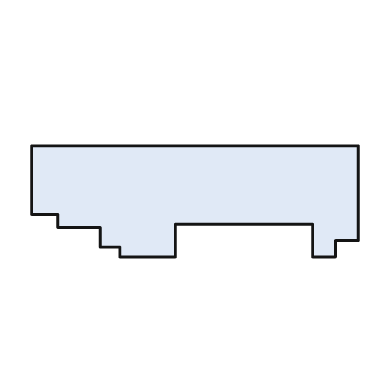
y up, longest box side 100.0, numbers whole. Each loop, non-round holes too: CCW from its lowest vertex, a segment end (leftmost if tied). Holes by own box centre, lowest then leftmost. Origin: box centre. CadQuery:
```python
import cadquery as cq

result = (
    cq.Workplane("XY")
    .moveTo(-23.0, -17.0)
    .lineTo(-6.0, -17.0)
    .lineTo(-6.0, -7.0)
    .lineTo(36.0, -7.0)
    .lineTo(36.0, -17.0)
    .lineTo(43.0, -17.0)
    .lineTo(43.0, -12.0)
    .lineTo(50.0, -12.0)
    .lineTo(50.0, 17.0)
    .lineTo(-50.0, 17.0)
    .lineTo(-50.0, -4.0)
    .lineTo(-42.0, -4.0)
    .lineTo(-42.0, -8.0)
    .lineTo(-29.0, -8.0)
    .lineTo(-29.0, -14.0)
    .lineTo(-23.0, -14.0)
    .close()
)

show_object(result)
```